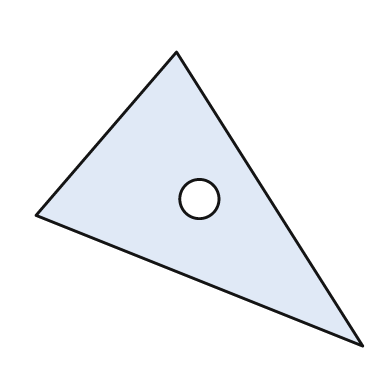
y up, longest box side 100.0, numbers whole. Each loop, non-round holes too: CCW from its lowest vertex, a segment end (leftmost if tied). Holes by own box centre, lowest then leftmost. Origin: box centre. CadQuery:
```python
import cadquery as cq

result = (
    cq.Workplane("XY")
    .moveTo(50.0, -45.0)
    .lineTo(-7.0, 45.0)
    .lineTo(-50.0, -5.0)
    .close()
    .moveTo(0.0, 0.0)
    .circle(6.0)
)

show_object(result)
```